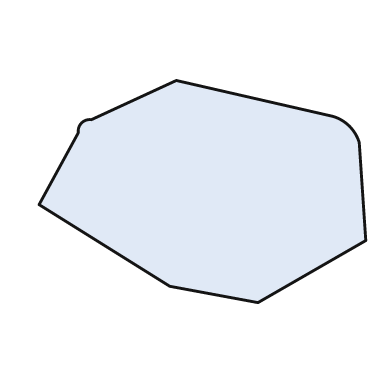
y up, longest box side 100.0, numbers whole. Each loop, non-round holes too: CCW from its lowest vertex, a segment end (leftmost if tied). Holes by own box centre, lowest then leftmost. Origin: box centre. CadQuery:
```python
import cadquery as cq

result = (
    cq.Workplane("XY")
    .moveTo(17.0, -34.0)
    .lineTo(50.0, -15.0)
    .lineTo(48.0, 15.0)
    .threePointArc((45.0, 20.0), (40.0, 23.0))
    .lineTo(-8.0, 34.0)
    .lineTo(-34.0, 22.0)
    .threePointArc((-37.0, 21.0), (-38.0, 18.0))
    .lineTo(-50.0, -4.0)
    .lineTo(-10.0, -29.0)
    .close()
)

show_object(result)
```